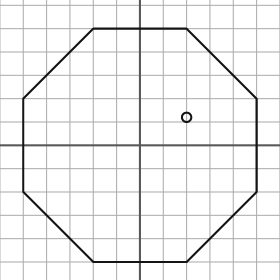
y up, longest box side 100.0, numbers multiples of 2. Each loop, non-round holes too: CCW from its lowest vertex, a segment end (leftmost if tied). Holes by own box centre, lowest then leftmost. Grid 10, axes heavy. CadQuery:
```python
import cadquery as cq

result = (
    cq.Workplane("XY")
    .moveTo(-20.0, -50.0)
    .lineTo(20.0, -50.0)
    .lineTo(50.0, -20.0)
    .lineTo(50.0, 20.0)
    .lineTo(20.0, 50.0)
    .lineTo(-20.0, 50.0)
    .lineTo(-50.0, 20.0)
    .lineTo(-50.0, -20.0)
    .close()
    .moveTo(20.0, 12.0)
    .circle(2.0)
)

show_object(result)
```